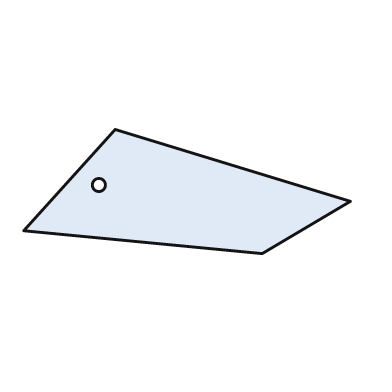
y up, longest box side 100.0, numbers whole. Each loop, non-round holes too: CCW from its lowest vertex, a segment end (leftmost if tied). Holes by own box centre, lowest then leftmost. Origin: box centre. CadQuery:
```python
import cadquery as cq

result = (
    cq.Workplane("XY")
    .moveTo(23.0, -19.0)
    .lineTo(50.0, -3.0)
    .lineTo(-22.0, 19.0)
    .lineTo(-50.0, -12.0)
    .close()
    .moveTo(-27.0, 2.0)
    .circle(2.0)
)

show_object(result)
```